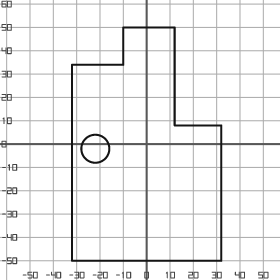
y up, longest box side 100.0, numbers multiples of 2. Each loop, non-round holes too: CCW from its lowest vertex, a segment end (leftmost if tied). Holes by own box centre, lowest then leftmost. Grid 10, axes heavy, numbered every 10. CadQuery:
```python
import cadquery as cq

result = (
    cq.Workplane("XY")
    .moveTo(-32.0, -50.0)
    .lineTo(32.0, -50.0)
    .lineTo(32.0, 8.0)
    .lineTo(12.0, 8.0)
    .lineTo(12.0, 50.0)
    .lineTo(-10.0, 50.0)
    .lineTo(-10.0, 34.0)
    .lineTo(-32.0, 34.0)
    .close()
    .moveTo(-22.0, -2.0)
    .circle(6.0)
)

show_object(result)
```